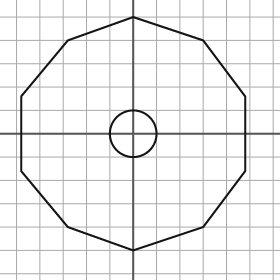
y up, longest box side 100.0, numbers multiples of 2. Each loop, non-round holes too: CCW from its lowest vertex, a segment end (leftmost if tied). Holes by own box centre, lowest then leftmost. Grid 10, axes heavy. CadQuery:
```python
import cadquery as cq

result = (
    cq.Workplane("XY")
    .moveTo(0.0, -50.0)
    .lineTo(30.0, -40.0)
    .lineTo(48.0, -16.0)
    .lineTo(48.0, 16.0)
    .lineTo(30.0, 40.0)
    .lineTo(0.0, 50.0)
    .lineTo(-28.0, 40.0)
    .lineTo(-48.0, 16.0)
    .lineTo(-48.0, -16.0)
    .lineTo(-28.0, -40.0)
    .close()
    .moveTo(0.0, 0.0)
    .circle(10.0)
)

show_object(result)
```